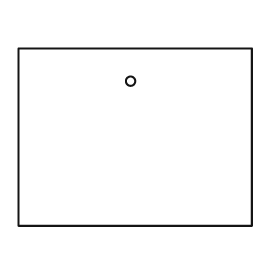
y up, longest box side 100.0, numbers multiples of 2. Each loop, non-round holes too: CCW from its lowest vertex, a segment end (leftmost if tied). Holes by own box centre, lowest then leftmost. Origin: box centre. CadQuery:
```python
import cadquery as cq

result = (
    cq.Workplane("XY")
    .moveTo(-50.0, -38.0)
    .lineTo(50.0, -38.0)
    .lineTo(50.0, 38.0)
    .lineTo(-50.0, 38.0)
    .close()
    .moveTo(-2.0, 24.0)
    .circle(2.0)
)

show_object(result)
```